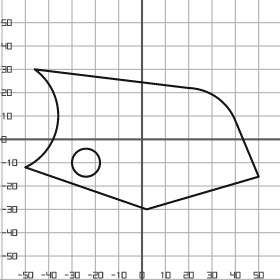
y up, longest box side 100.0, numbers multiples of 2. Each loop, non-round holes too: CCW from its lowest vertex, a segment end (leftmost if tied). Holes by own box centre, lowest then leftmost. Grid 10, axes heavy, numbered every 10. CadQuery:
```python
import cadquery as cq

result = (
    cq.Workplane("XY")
    .moveTo(2.0, -30.0)
    .lineTo(50.0, -16.0)
    .lineTo(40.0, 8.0)
    .threePointArc((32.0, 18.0), (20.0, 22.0))
    .lineTo(-46.0, 30.0)
    .threePointArc((-36.0, 8.0), (-50.0, -12.0))
    .close()
    .moveTo(-24.0, -10.0)
    .circle(6.0)
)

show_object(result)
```